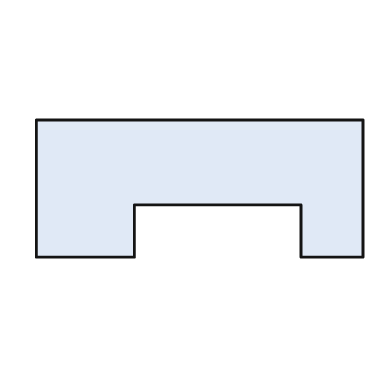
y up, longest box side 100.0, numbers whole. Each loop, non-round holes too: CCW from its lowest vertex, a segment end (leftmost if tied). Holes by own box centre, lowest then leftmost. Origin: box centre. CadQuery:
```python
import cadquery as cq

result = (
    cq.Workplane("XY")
    .moveTo(-50.0, -21.0)
    .lineTo(-20.0, -21.0)
    .lineTo(-20.0, -5.0)
    .lineTo(31.0, -5.0)
    .lineTo(31.0, -21.0)
    .lineTo(50.0, -21.0)
    .lineTo(50.0, 21.0)
    .lineTo(-50.0, 21.0)
    .close()
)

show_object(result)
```